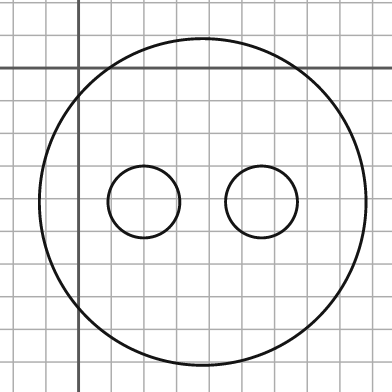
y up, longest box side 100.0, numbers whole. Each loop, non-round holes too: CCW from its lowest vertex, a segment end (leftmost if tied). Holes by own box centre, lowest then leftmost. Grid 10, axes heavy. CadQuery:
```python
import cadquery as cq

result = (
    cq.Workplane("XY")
    .moveTo(38.0, -41.0)
    .circle(50.0)
    .moveTo(20.0, -41.0)
    .circle(11.0)
    .moveTo(56.0, -41.0)
    .circle(11.0)
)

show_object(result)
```